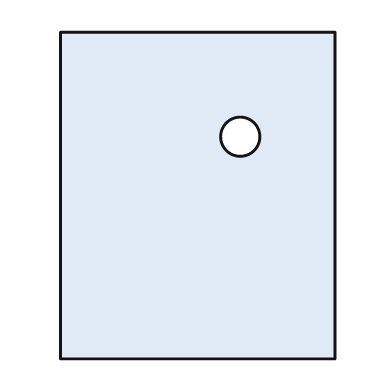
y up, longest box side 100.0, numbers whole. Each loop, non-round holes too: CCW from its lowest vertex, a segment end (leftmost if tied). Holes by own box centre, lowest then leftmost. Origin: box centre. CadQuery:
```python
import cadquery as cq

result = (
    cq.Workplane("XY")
    .moveTo(-42.0, -50.0)
    .lineTo(42.0, -50.0)
    .lineTo(42.0, 50.0)
    .lineTo(-42.0, 50.0)
    .close()
    .moveTo(13.0, 18.0)
    .circle(6.0)
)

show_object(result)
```